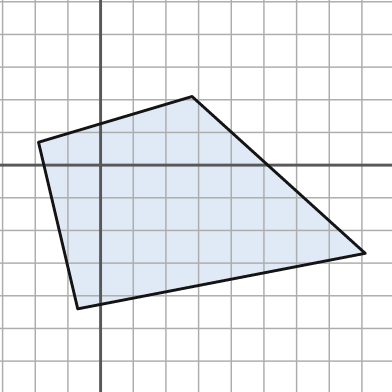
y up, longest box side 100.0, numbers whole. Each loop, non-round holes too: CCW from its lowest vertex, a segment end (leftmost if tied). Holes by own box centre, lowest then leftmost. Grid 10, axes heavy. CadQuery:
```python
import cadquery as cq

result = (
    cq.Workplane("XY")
    .moveTo(-7.0, -44.0)
    .lineTo(81.0, -27.0)
    .lineTo(28.0, 21.0)
    .lineTo(-19.0, 7.0)
    .close()
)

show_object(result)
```